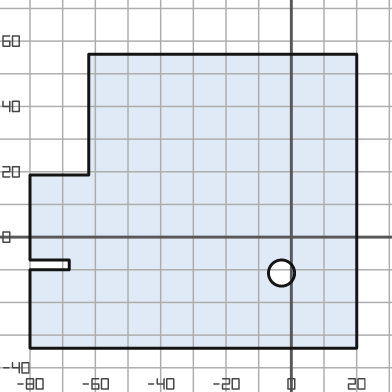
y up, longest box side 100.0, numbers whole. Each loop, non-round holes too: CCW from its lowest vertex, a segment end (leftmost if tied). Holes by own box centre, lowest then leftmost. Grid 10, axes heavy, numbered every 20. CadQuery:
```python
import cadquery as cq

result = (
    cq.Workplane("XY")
    .moveTo(-80.0, -34.0)
    .lineTo(20.0, -34.0)
    .lineTo(20.0, 56.0)
    .lineTo(-62.0, 56.0)
    .lineTo(-62.0, 19.0)
    .lineTo(-80.0, 19.0)
    .lineTo(-80.0, -7.0)
    .lineTo(-68.0, -7.0)
    .lineTo(-68.0, -10.0)
    .lineTo(-80.0, -10.0)
    .close()
    .moveTo(-3.0, -11.0)
    .circle(4.0)
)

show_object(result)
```